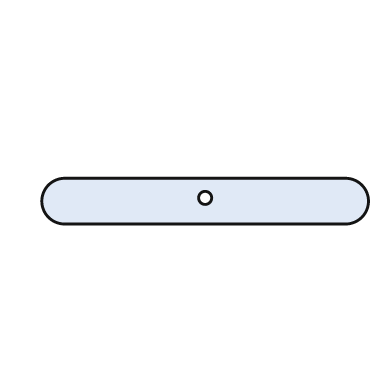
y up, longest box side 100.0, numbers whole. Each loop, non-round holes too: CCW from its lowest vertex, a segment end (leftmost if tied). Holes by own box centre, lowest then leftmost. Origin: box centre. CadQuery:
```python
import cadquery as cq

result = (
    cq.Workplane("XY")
    .moveTo(-43.0, -7.0)
    .lineTo(43.0, -7.0)
    .threePointArc((50.0, 0.0), (43.0, 7.0))
    .lineTo(-43.0, 7.0)
    .threePointArc((-50.0, 0.0), (-43.0, -7.0))
    .close()
    .moveTo(0.0, 1.0)
    .circle(2.0)
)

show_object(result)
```